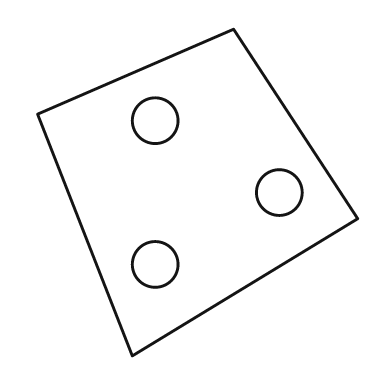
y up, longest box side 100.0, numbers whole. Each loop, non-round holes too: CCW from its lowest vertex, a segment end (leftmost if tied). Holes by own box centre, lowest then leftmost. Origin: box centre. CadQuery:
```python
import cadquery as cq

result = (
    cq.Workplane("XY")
    .moveTo(-20.0, -50.0)
    .lineTo(49.0, -8.0)
    .lineTo(11.0, 50.0)
    .lineTo(-49.0, 24.0)
    .close()
    .moveTo(-13.0, -22.0)
    .circle(7.0)
    .moveTo(25.0, 0.0)
    .circle(7.0)
    .moveTo(-13.0, 22.0)
    .circle(7.0)
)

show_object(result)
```